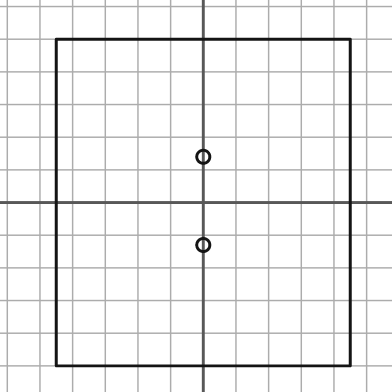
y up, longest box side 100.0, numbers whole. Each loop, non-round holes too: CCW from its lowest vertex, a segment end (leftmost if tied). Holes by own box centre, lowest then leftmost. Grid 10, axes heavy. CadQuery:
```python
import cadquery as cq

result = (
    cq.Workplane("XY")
    .moveTo(-45.0, -50.0)
    .lineTo(45.0, -50.0)
    .lineTo(45.0, 50.0)
    .lineTo(-45.0, 50.0)
    .close()
    .moveTo(0.0, -13.0)
    .circle(2.0)
    .moveTo(0.0, 14.0)
    .circle(2.0)
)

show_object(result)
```